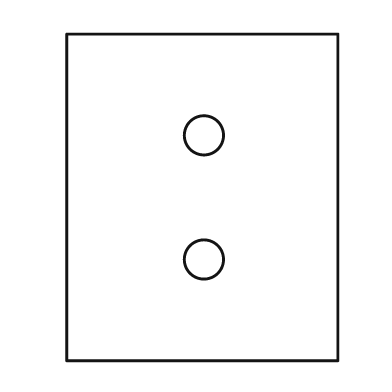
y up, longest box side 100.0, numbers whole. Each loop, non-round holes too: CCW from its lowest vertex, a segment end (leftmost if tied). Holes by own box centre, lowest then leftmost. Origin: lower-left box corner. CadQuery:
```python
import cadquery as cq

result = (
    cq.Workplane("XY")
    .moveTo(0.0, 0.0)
    .lineTo(83.0, 0.0)
    .lineTo(83.0, 100.0)
    .lineTo(0.0, 100.0)
    .close()
    .moveTo(42.0, 31.0)
    .circle(6.0)
    .moveTo(42.0, 69.0)
    .circle(6.0)
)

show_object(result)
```